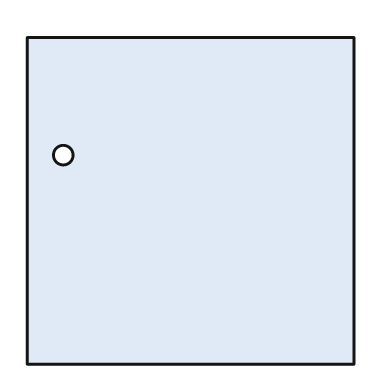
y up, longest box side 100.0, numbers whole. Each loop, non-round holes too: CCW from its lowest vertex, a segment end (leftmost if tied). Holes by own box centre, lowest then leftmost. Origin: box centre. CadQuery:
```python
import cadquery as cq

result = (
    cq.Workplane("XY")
    .moveTo(-50.0, -50.0)
    .lineTo(50.0, -50.0)
    .lineTo(50.0, 50.0)
    .lineTo(-50.0, 50.0)
    .close()
    .moveTo(-39.0, 14.0)
    .circle(3.0)
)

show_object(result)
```